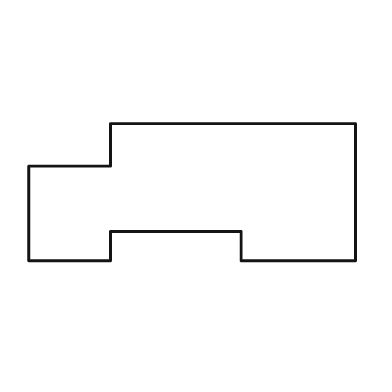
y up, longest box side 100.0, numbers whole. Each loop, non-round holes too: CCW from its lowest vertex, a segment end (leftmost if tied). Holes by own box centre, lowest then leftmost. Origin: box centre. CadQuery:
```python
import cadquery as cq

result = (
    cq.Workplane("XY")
    .moveTo(-50.0, -21.0)
    .lineTo(-25.0, -21.0)
    .lineTo(-25.0, -12.0)
    .lineTo(15.0, -12.0)
    .lineTo(15.0, -21.0)
    .lineTo(50.0, -21.0)
    .lineTo(50.0, 21.0)
    .lineTo(-25.0, 21.0)
    .lineTo(-25.0, 8.0)
    .lineTo(-50.0, 8.0)
    .close()
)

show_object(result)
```